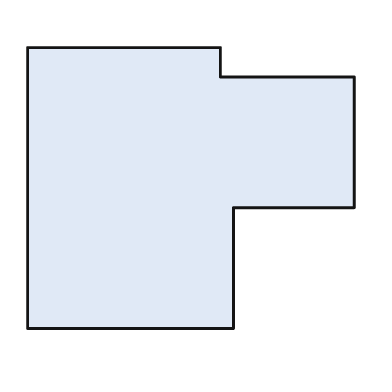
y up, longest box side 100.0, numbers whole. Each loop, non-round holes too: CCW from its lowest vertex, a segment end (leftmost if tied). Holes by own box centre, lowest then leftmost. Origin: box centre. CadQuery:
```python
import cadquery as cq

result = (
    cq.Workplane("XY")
    .moveTo(-50.0, -43.0)
    .lineTo(13.0, -43.0)
    .lineTo(13.0, -6.0)
    .lineTo(50.0, -6.0)
    .lineTo(50.0, 34.0)
    .lineTo(9.0, 34.0)
    .lineTo(9.0, 43.0)
    .lineTo(-50.0, 43.0)
    .close()
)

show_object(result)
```